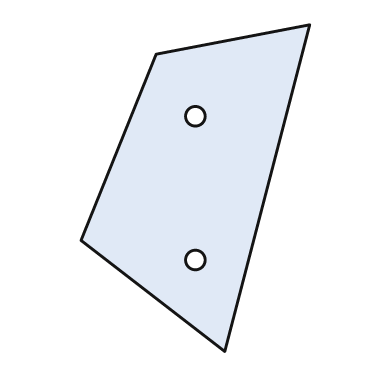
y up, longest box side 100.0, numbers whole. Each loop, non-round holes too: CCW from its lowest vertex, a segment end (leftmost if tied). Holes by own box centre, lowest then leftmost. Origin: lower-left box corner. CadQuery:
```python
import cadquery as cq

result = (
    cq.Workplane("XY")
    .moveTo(44.0, 0.0)
    .lineTo(70.0, 100.0)
    .lineTo(23.0, 91.0)
    .lineTo(0.0, 34.0)
    .close()
    .moveTo(35.0, 28.0)
    .circle(3.0)
    .moveTo(35.0, 72.0)
    .circle(3.0)
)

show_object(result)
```